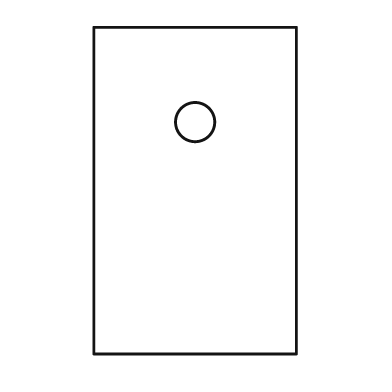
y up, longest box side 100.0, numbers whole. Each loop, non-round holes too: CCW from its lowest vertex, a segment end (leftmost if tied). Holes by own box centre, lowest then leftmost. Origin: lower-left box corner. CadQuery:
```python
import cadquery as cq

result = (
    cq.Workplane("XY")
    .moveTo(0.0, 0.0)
    .lineTo(62.0, 0.0)
    .lineTo(62.0, 100.0)
    .lineTo(0.0, 100.0)
    .close()
    .moveTo(31.0, 71.0)
    .circle(6.0)
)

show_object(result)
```